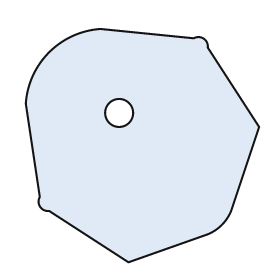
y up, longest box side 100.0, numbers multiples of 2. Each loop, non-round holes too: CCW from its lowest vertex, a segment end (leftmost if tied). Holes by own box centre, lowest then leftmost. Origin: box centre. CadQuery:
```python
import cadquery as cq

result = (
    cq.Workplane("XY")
    .moveTo(-6.0, -50.0)
    .lineTo(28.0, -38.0)
    .threePointArc((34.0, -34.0), (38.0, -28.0))
    .lineTo(50.0, 8.0)
    .lineTo(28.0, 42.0)
    .threePointArc((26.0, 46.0), (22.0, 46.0))
    .lineTo(-18.0, 50.0)
    .threePointArc((-40.0, 40.0), (-50.0, 18.0))
    .lineTo(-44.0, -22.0)
    .threePointArc((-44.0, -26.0), (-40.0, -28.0))
    .close()
    .moveTo(-10.0, 14.0)
    .circle(6.0)
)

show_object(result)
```